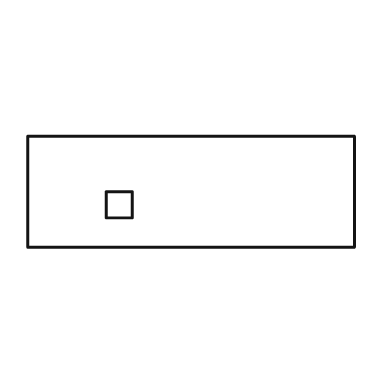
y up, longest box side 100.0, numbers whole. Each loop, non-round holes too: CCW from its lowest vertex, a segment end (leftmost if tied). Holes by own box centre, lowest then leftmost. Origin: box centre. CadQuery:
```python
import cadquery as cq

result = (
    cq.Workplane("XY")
    .moveTo(-50.0, -17.0)
    .lineTo(50.0, -17.0)
    .lineTo(50.0, 17.0)
    .lineTo(-50.0, 17.0)
    .close()
    .moveTo(-26.0, -8.0)
    .lineTo(-18.0, -8.0)
    .lineTo(-18.0, 0.0)
    .lineTo(-26.0, 0.0)
    .close()
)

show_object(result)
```